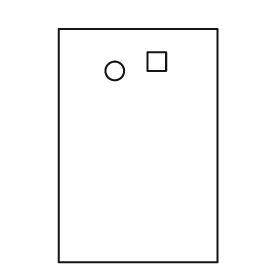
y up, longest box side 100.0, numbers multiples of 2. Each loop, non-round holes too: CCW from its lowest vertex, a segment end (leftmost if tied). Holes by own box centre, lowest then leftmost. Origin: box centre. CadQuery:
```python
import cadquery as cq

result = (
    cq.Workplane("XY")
    .moveTo(-34.0, -50.0)
    .lineTo(34.0, -50.0)
    .lineTo(34.0, 50.0)
    .lineTo(-34.0, 50.0)
    .close()
    .moveTo(-10.0, 32.0)
    .circle(4.0)
    .moveTo(4.0, 32.0)
    .lineTo(12.0, 32.0)
    .lineTo(12.0, 40.0)
    .lineTo(4.0, 40.0)
    .close()
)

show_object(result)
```